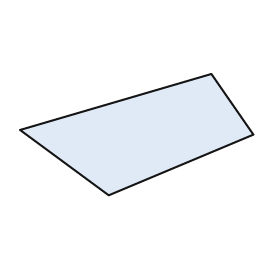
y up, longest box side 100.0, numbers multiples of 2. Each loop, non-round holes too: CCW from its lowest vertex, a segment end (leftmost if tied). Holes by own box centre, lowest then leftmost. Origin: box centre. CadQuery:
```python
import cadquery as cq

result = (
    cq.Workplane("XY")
    .moveTo(-12.0, -26.0)
    .lineTo(50.0, 0.0)
    .lineTo(32.0, 26.0)
    .lineTo(-50.0, 2.0)
    .close()
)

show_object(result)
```